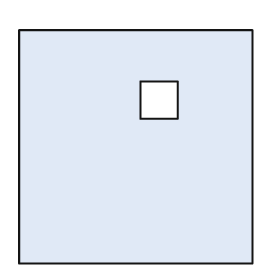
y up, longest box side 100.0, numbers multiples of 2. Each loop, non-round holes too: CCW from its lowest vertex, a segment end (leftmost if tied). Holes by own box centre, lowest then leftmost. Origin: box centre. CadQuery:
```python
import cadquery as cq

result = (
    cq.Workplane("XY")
    .moveTo(-50.0, -50.0)
    .lineTo(50.0, -50.0)
    .lineTo(50.0, 50.0)
    .lineTo(-50.0, 50.0)
    .close()
    .moveTo(2.0, 12.0)
    .lineTo(18.0, 12.0)
    .lineTo(18.0, 28.0)
    .lineTo(2.0, 28.0)
    .close()
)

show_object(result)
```